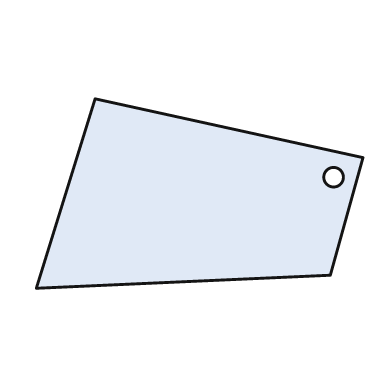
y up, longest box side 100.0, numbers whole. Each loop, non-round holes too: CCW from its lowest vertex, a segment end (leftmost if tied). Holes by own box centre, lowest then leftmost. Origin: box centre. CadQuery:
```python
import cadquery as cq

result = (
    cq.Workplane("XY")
    .moveTo(-50.0, -29.0)
    .lineTo(40.0, -25.0)
    .lineTo(50.0, 11.0)
    .lineTo(-32.0, 29.0)
    .close()
    .moveTo(41.0, 5.0)
    .circle(3.0)
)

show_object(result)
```